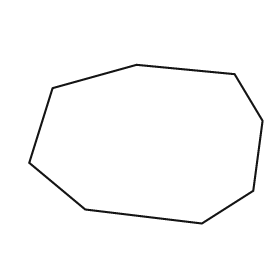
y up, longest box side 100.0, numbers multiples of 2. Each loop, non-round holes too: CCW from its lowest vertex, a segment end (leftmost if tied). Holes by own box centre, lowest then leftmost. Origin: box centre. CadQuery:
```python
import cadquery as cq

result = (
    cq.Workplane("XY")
    .moveTo(24.0, -34.0)
    .lineTo(46.0, -20.0)
    .lineTo(50.0, 10.0)
    .lineTo(38.0, 30.0)
    .lineTo(-4.0, 34.0)
    .lineTo(-40.0, 24.0)
    .lineTo(-50.0, -8.0)
    .lineTo(-26.0, -28.0)
    .close()
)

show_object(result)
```